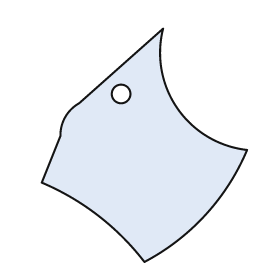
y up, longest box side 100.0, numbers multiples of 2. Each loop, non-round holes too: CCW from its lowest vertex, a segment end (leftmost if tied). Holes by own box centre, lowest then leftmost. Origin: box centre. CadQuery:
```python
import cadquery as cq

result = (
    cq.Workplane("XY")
    .moveTo(0.0, -50.0)
    .threePointArc((26.0, -30.0), (44.0, -2.0))
    .threePointArc((14.0, 16.0), (8.0, 50.0))
    .lineTo(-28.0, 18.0)
    .threePointArc((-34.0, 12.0), (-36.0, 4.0))
    .lineTo(-44.0, -16.0)
    .threePointArc((-20.0, -30.0), (0.0, -50.0))
    .close()
    .moveTo(-10.0, 22.0)
    .circle(4.0)
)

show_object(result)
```